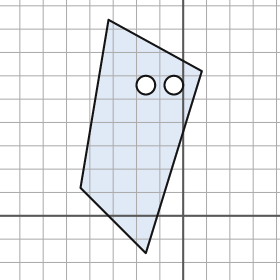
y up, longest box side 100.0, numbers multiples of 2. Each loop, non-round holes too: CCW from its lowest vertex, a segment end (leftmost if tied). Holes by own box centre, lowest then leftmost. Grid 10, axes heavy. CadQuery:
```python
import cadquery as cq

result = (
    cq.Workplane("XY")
    .moveTo(-16.0, -16.0)
    .lineTo(8.0, 62.0)
    .lineTo(-32.0, 84.0)
    .lineTo(-44.0, 12.0)
    .close()
    .moveTo(-16.0, 56.0)
    .circle(4.0)
    .moveTo(-4.0, 56.0)
    .circle(4.0)
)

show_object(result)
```